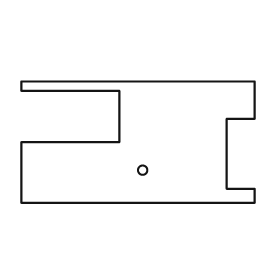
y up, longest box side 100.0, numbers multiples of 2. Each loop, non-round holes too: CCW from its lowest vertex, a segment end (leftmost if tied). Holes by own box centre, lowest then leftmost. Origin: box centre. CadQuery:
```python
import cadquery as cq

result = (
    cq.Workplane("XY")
    .moveTo(-50.0, -26.0)
    .lineTo(50.0, -26.0)
    .lineTo(50.0, -20.0)
    .lineTo(38.0, -20.0)
    .lineTo(38.0, 10.0)
    .lineTo(50.0, 10.0)
    .lineTo(50.0, 26.0)
    .lineTo(-50.0, 26.0)
    .lineTo(-50.0, 22.0)
    .lineTo(-8.0, 22.0)
    .lineTo(-8.0, 0.0)
    .lineTo(-50.0, 0.0)
    .close()
    .moveTo(2.0, -12.0)
    .circle(2.0)
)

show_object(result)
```